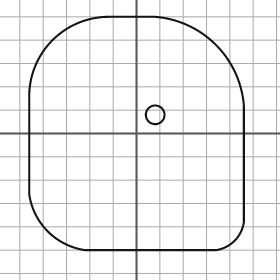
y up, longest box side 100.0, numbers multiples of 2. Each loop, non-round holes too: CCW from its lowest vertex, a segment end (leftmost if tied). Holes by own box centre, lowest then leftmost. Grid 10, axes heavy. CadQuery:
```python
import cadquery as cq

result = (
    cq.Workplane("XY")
    .moveTo(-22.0, -50.0)
    .lineTo(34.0, -50.0)
    .threePointArc((42.0, -46.0), (46.0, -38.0))
    .lineTo(46.0, 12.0)
    .threePointArc((34.0, 38.0), (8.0, 50.0))
    .lineTo(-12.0, 50.0)
    .threePointArc((-36.0, 40.0), (-46.0, 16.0))
    .lineTo(-46.0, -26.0)
    .threePointArc((-38.0, -42.0), (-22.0, -50.0))
    .close()
    .moveTo(8.0, 8.0)
    .circle(4.0)
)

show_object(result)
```